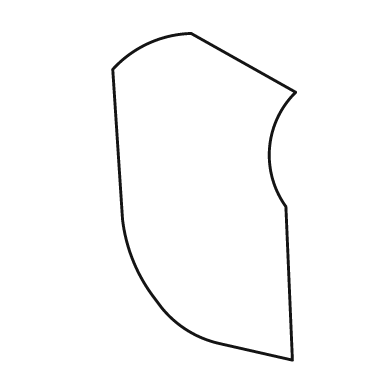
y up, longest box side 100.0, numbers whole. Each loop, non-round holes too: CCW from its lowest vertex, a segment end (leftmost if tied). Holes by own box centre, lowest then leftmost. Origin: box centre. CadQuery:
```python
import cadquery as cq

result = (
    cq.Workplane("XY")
    .moveTo(27.0, -50.0)
    .lineTo(25.0, -3.0)
    .threePointArc((20.0, 15.0), (28.0, 32.0))
    .lineTo(-4.0, 50.0)
    .threePointArc((-17.0, 47.0), (-28.0, 39.0))
    .lineTo(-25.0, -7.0)
    .threePointArc((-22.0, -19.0), (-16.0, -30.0))
    .lineTo(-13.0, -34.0)
    .threePointArc((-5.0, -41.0), (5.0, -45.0))
    .close()
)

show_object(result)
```